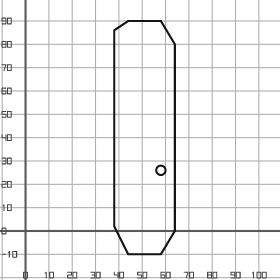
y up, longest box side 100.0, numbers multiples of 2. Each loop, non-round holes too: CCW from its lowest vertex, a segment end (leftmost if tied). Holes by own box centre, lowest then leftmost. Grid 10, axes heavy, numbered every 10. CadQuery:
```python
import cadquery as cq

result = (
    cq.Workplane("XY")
    .moveTo(44.0, -10.0)
    .lineTo(58.0, -10.0)
    .lineTo(64.0, 0.0)
    .lineTo(64.0, 80.0)
    .lineTo(58.0, 90.0)
    .lineTo(44.0, 90.0)
    .lineTo(38.0, 86.0)
    .lineTo(38.0, 2.0)
    .close()
    .moveTo(58.0, 26.0)
    .circle(2.0)
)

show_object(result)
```